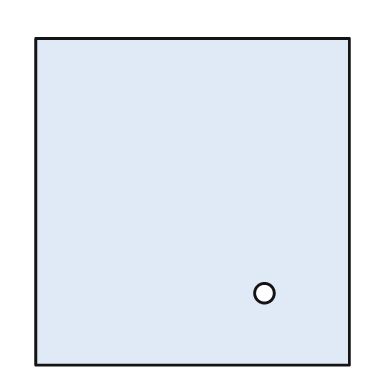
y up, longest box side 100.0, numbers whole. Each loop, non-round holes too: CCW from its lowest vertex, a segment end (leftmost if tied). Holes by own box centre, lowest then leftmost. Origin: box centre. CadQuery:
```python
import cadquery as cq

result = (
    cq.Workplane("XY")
    .moveTo(-48.0, -50.0)
    .lineTo(48.0, -50.0)
    .lineTo(48.0, 50.0)
    .lineTo(-48.0, 50.0)
    .close()
    .moveTo(22.0, -28.0)
    .circle(3.0)
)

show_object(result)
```